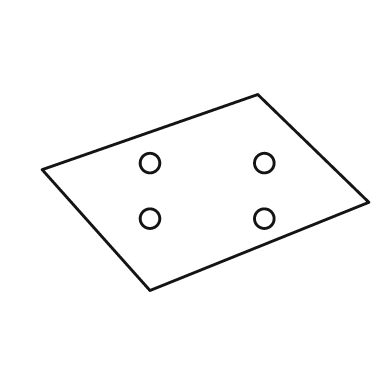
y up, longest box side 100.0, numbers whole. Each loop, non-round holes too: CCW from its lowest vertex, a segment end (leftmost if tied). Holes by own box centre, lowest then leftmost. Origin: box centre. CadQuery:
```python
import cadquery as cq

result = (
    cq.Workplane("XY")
    .moveTo(-17.0, -30.0)
    .lineTo(50.0, -3.0)
    .lineTo(16.0, 30.0)
    .lineTo(-50.0, 7.0)
    .close()
    .moveTo(-17.0, -8.0)
    .circle(3.0)
    .moveTo(18.0, -8.0)
    .circle(3.0)
    .moveTo(-17.0, 9.0)
    .circle(3.0)
    .moveTo(18.0, 9.0)
    .circle(3.0)
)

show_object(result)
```